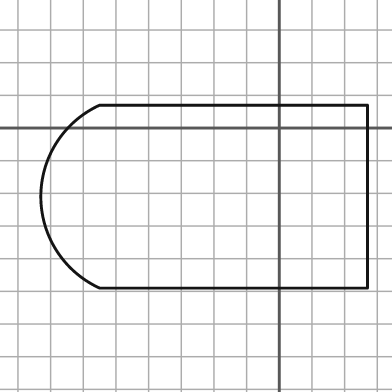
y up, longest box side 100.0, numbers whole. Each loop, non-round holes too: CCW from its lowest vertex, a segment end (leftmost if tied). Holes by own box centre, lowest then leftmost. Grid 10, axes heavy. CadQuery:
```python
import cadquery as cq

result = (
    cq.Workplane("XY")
    .moveTo(-55.0, -49.0)
    .lineTo(27.0, -49.0)
    .lineTo(27.0, 7.0)
    .lineTo(-55.0, 7.0)
    .threePointArc((-73.0, -21.0), (-55.0, -49.0))
    .close()
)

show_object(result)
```